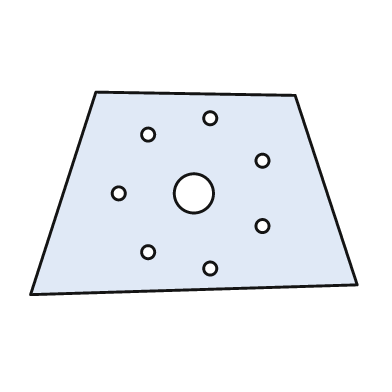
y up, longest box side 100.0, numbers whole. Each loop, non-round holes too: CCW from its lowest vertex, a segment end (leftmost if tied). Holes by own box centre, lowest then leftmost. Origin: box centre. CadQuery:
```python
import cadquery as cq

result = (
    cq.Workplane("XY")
    .moveTo(-50.0, -31.0)
    .lineTo(50.0, -28.0)
    .lineTo(31.0, 30.0)
    .lineTo(-30.0, 31.0)
    .close()
    .moveTo(5.0, -23.0)
    .circle(2.0)
    .moveTo(-14.0, -18.0)
    .circle(2.0)
    .moveTo(21.0, -10.0)
    .circle(2.0)
    .moveTo(-23.0, 0.0)
    .circle(2.0)
    .moveTo(0.0, 0.0)
    .circle(6.0)
    .moveTo(21.0, 10.0)
    .circle(2.0)
    .moveTo(-14.0, 18.0)
    .circle(2.0)
    .moveTo(5.0, 23.0)
    .circle(2.0)
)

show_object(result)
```